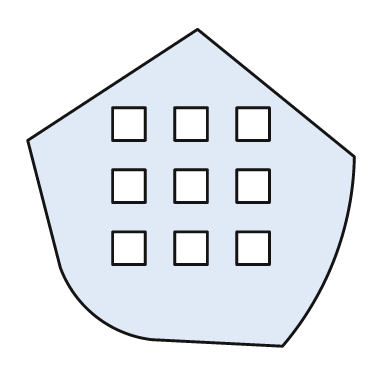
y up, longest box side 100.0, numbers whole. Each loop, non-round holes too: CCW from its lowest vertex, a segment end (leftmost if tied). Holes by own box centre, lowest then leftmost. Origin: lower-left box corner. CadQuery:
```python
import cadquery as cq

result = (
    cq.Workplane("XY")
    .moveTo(78.0, 0.0)
    .threePointArc((94.0, 27.0), (100.0, 58.0))
    .lineTo(52.0, 97.0)
    .lineTo(0.0, 63.0)
    .lineTo(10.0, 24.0)
    .threePointArc((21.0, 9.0), (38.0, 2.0))
    .close()
    .moveTo(26.0, 25.0)
    .lineTo(36.0, 25.0)
    .lineTo(36.0, 35.0)
    .lineTo(26.0, 35.0)
    .close()
    .moveTo(45.0, 25.0)
    .lineTo(55.0, 25.0)
    .lineTo(55.0, 35.0)
    .lineTo(45.0, 35.0)
    .close()
    .moveTo(64.0, 25.0)
    .lineTo(74.0, 25.0)
    .lineTo(74.0, 35.0)
    .lineTo(64.0, 35.0)
    .close()
    .moveTo(26.0, 44.0)
    .lineTo(36.0, 44.0)
    .lineTo(36.0, 54.0)
    .lineTo(26.0, 54.0)
    .close()
    .moveTo(45.0, 44.0)
    .lineTo(55.0, 44.0)
    .lineTo(55.0, 54.0)
    .lineTo(45.0, 54.0)
    .close()
    .moveTo(64.0, 44.0)
    .lineTo(74.0, 44.0)
    .lineTo(74.0, 54.0)
    .lineTo(64.0, 54.0)
    .close()
    .moveTo(26.0, 63.0)
    .lineTo(36.0, 63.0)
    .lineTo(36.0, 73.0)
    .lineTo(26.0, 73.0)
    .close()
    .moveTo(45.0, 63.0)
    .lineTo(55.0, 63.0)
    .lineTo(55.0, 73.0)
    .lineTo(45.0, 73.0)
    .close()
    .moveTo(64.0, 63.0)
    .lineTo(74.0, 63.0)
    .lineTo(74.0, 73.0)
    .lineTo(64.0, 73.0)
    .close()
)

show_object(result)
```